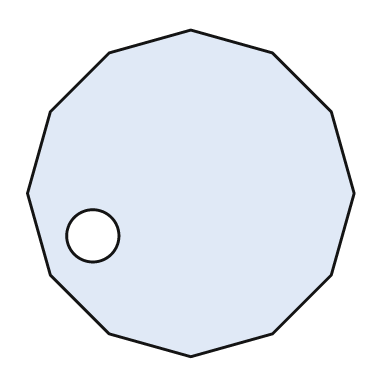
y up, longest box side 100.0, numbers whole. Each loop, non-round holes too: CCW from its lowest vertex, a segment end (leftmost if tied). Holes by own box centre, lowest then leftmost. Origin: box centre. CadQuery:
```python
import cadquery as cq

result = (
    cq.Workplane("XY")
    .moveTo(0.0, -50.0)
    .lineTo(25.0, -43.0)
    .lineTo(43.0, -25.0)
    .lineTo(50.0, 0.0)
    .lineTo(43.0, 25.0)
    .lineTo(25.0, 43.0)
    .lineTo(0.0, 50.0)
    .lineTo(-25.0, 43.0)
    .lineTo(-43.0, 25.0)
    .lineTo(-50.0, 0.0)
    .lineTo(-43.0, -25.0)
    .lineTo(-25.0, -43.0)
    .close()
    .moveTo(-30.0, -13.0)
    .circle(8.0)
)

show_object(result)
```